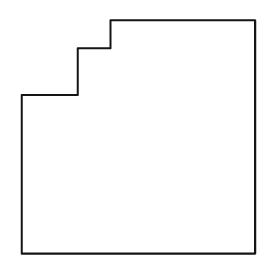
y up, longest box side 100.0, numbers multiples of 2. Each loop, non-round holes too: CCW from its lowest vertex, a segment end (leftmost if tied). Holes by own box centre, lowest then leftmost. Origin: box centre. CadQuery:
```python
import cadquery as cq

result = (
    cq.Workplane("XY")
    .moveTo(-50.0, -50.0)
    .lineTo(50.0, -50.0)
    .lineTo(50.0, 50.0)
    .lineTo(-12.0, 50.0)
    .lineTo(-12.0, 38.0)
    .lineTo(-26.0, 38.0)
    .lineTo(-26.0, 18.0)
    .lineTo(-50.0, 18.0)
    .close()
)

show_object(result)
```